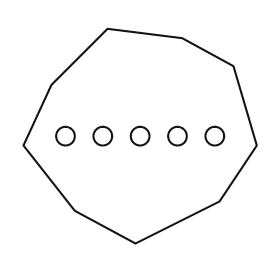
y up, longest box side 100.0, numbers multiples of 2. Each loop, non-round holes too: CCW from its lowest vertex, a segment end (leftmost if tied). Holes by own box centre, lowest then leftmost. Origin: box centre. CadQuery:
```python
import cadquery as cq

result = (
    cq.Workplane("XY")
    .moveTo(-2.0, -46.0)
    .lineTo(34.0, -28.0)
    .lineTo(50.0, -4.0)
    .lineTo(40.0, 30.0)
    .lineTo(18.0, 42.0)
    .lineTo(-14.0, 46.0)
    .lineTo(-38.0, 22.0)
    .lineTo(-50.0, -4.0)
    .lineTo(-28.0, -32.0)
    .close()
    .moveTo(-32.0, 0.0)
    .circle(4.0)
    .moveTo(-16.0, 0.0)
    .circle(4.0)
    .moveTo(0.0, 0.0)
    .circle(4.0)
    .moveTo(16.0, 0.0)
    .circle(4.0)
    .moveTo(32.0, 0.0)
    .circle(4.0)
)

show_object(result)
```